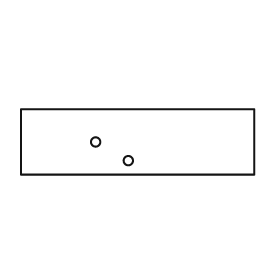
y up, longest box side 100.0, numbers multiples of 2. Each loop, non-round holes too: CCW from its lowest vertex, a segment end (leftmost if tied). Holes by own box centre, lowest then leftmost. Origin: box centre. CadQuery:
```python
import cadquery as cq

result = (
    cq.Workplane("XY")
    .moveTo(-50.0, -14.0)
    .lineTo(50.0, -14.0)
    .lineTo(50.0, 14.0)
    .lineTo(-50.0, 14.0)
    .close()
    .moveTo(-4.0, -8.0)
    .circle(2.0)
    .moveTo(-18.0, 0.0)
    .circle(2.0)
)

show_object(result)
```